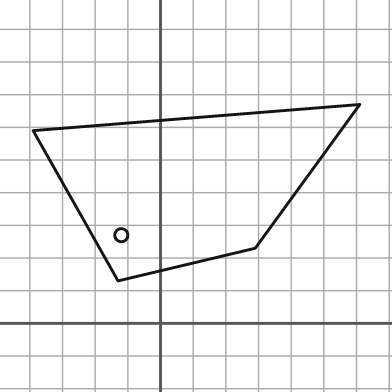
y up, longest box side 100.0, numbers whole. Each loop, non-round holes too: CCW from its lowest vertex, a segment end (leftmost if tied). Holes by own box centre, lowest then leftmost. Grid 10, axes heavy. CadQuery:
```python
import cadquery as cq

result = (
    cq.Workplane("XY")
    .moveTo(-13.0, 13.0)
    .lineTo(29.0, 23.0)
    .lineTo(61.0, 67.0)
    .lineTo(-39.0, 59.0)
    .close()
    .moveTo(-12.0, 27.0)
    .circle(2.0)
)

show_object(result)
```